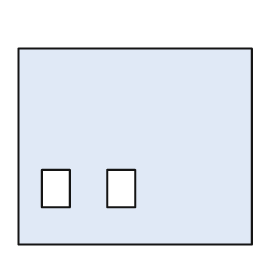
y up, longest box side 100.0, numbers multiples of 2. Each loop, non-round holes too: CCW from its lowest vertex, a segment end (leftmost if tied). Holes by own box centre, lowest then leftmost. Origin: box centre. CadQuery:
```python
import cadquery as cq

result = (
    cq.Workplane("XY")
    .moveTo(-50.0, -42.0)
    .lineTo(50.0, -42.0)
    .lineTo(50.0, 42.0)
    .lineTo(-50.0, 42.0)
    .close()
    .moveTo(-40.0, -26.0)
    .lineTo(-28.0, -26.0)
    .lineTo(-28.0, -10.0)
    .lineTo(-40.0, -10.0)
    .close()
    .moveTo(-12.0, -26.0)
    .lineTo(0.0, -26.0)
    .lineTo(0.0, -10.0)
    .lineTo(-12.0, -10.0)
    .close()
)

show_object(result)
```